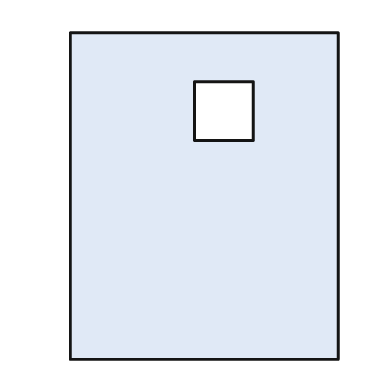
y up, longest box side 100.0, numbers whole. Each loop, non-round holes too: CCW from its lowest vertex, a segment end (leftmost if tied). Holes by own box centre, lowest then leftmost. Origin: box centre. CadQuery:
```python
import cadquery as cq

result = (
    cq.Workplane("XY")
    .moveTo(-41.0, -50.0)
    .lineTo(41.0, -50.0)
    .lineTo(41.0, 50.0)
    .lineTo(-41.0, 50.0)
    .close()
    .moveTo(-3.0, 17.0)
    .lineTo(15.0, 17.0)
    .lineTo(15.0, 35.0)
    .lineTo(-3.0, 35.0)
    .close()
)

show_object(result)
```